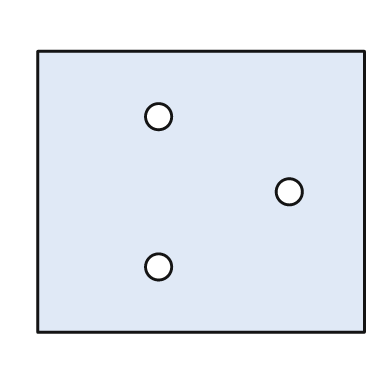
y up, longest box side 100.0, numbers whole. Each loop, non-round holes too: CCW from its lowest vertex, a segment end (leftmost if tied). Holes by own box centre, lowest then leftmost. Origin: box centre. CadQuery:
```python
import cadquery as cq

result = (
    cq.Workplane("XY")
    .moveTo(-50.0, -43.0)
    .lineTo(50.0, -43.0)
    .lineTo(50.0, 43.0)
    .lineTo(-50.0, 43.0)
    .close()
    .moveTo(-13.0, -23.0)
    .circle(4.0)
    .moveTo(27.0, 0.0)
    .circle(4.0)
    .moveTo(-13.0, 23.0)
    .circle(4.0)
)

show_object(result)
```